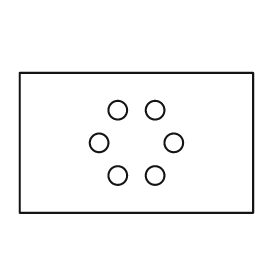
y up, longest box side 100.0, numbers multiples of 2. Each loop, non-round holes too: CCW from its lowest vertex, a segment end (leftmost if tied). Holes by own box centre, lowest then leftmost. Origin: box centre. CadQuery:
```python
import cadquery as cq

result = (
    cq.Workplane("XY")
    .moveTo(-50.0, -30.0)
    .lineTo(50.0, -30.0)
    .lineTo(50.0, 30.0)
    .lineTo(-50.0, 30.0)
    .close()
    .moveTo(-8.0, -14.0)
    .circle(4.0)
    .moveTo(8.0, -14.0)
    .circle(4.0)
    .moveTo(-16.0, 0.0)
    .circle(4.0)
    .moveTo(16.0, 0.0)
    .circle(4.0)
    .moveTo(-8.0, 14.0)
    .circle(4.0)
    .moveTo(8.0, 14.0)
    .circle(4.0)
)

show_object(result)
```